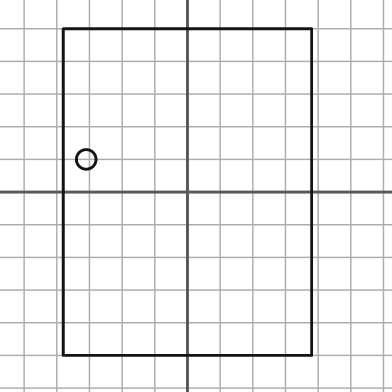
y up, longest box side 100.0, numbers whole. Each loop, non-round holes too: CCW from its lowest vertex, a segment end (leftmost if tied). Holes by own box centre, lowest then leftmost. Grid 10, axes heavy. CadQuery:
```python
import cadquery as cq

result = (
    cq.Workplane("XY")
    .moveTo(-38.0, -50.0)
    .lineTo(38.0, -50.0)
    .lineTo(38.0, 50.0)
    .lineTo(-38.0, 50.0)
    .close()
    .moveTo(-31.0, 10.0)
    .circle(3.0)
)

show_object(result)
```